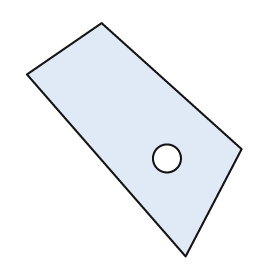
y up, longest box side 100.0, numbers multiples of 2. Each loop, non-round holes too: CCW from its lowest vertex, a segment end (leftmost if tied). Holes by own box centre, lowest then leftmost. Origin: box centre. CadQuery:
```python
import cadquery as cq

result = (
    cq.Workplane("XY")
    .moveTo(22.0, -50.0)
    .lineTo(46.0, -4.0)
    .lineTo(-14.0, 50.0)
    .lineTo(-46.0, 28.0)
    .close()
    .moveTo(14.0, -8.0)
    .circle(6.0)
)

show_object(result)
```